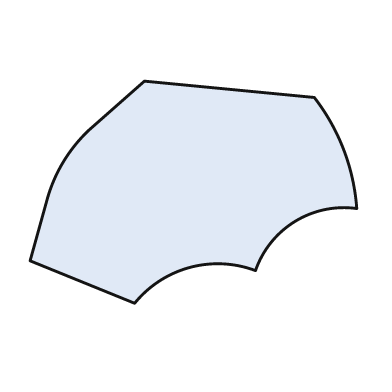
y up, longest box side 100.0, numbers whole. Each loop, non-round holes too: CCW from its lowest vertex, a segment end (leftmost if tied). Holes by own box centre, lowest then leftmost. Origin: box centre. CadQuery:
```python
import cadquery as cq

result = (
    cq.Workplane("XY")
    .moveTo(-18.0, -34.0)
    .threePointArc((-1.0, -23.0), (19.0, -24.0))
    .threePointArc((31.0, -9.0), (50.0, -5.0))
    .threePointArc((46.0, 13.0), (37.0, 29.0))
    .lineTo(-15.0, 34.0)
    .lineTo(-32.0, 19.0)
    .threePointArc((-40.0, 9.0), (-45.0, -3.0))
    .lineTo(-50.0, -21.0)
    .close()
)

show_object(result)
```